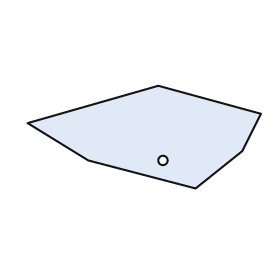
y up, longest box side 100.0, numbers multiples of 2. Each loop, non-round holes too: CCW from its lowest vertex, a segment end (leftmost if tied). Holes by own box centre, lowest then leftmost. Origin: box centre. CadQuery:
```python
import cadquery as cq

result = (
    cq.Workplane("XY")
    .moveTo(22.0, -22.0)
    .lineTo(42.0, -6.0)
    .lineTo(50.0, 10.0)
    .lineTo(6.0, 22.0)
    .lineTo(-50.0, 6.0)
    .lineTo(-24.0, -10.0)
    .close()
    .moveTo(8.0, -10.0)
    .circle(2.0)
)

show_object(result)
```